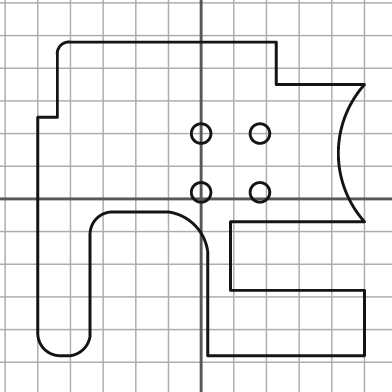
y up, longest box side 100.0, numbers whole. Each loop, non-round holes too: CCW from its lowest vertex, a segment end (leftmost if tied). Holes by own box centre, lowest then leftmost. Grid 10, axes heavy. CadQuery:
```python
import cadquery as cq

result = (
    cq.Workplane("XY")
    .moveTo(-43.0, -48.0)
    .lineTo(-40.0, -48.0)
    .threePointArc((-36.0, -46.0), (-34.0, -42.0))
    .lineTo(-34.0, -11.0)
    .threePointArc((-32.0, -6.0), (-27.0, -4.0))
    .lineTo(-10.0, -4.0)
    .threePointArc((-2.0, -8.0), (2.0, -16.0))
    .lineTo(2.0, -48.0)
    .lineTo(50.0, -48.0)
    .lineTo(50.0, -28.0)
    .lineTo(9.0, -28.0)
    .lineTo(9.0, -7.0)
    .lineTo(50.0, -7.0)
    .threePointArc((42.0, 14.0), (50.0, 35.0))
    .lineTo(23.0, 35.0)
    .lineTo(23.0, 48.0)
    .lineTo(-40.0, 48.0)
    .threePointArc((-43.0, 47.0), (-44.0, 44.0))
    .lineTo(-44.0, 25.0)
    .lineTo(-50.0, 25.0)
    .lineTo(-50.0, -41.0)
    .threePointArc((-48.0, -46.0), (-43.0, -48.0))
    .close()
    .moveTo(0.0, 2.0)
    .circle(3.0)
    .moveTo(18.0, 2.0)
    .circle(3.0)
    .moveTo(0.0, 20.0)
    .circle(3.0)
    .moveTo(18.0, 20.0)
    .circle(3.0)
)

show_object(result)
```